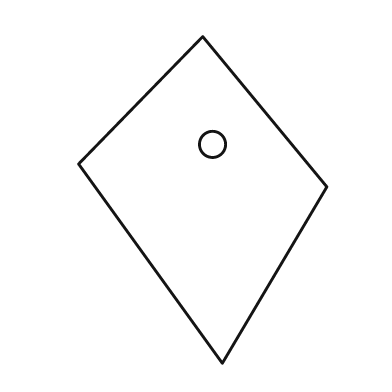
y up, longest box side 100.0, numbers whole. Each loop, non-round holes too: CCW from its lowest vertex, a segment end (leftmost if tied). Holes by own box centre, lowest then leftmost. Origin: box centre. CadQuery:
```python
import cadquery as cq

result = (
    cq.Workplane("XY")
    .moveTo(6.0, -50.0)
    .lineTo(38.0, 4.0)
    .lineTo(0.0, 50.0)
    .lineTo(-38.0, 11.0)
    .close()
    .moveTo(3.0, 17.0)
    .circle(4.0)
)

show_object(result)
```